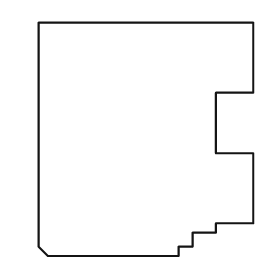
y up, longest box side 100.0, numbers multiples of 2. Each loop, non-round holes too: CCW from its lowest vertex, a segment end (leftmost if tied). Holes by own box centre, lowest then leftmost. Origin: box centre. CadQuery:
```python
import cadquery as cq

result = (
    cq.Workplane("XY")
    .moveTo(-42.0, -50.0)
    .lineTo(14.0, -50.0)
    .lineTo(14.0, -46.0)
    .lineTo(20.0, -46.0)
    .lineTo(20.0, -40.0)
    .lineTo(30.0, -40.0)
    .lineTo(30.0, -36.0)
    .lineTo(46.0, -36.0)
    .lineTo(46.0, -6.0)
    .lineTo(30.0, -6.0)
    .lineTo(30.0, 20.0)
    .lineTo(46.0, 20.0)
    .lineTo(46.0, 50.0)
    .lineTo(-46.0, 50.0)
    .lineTo(-46.0, -46.0)
    .close()
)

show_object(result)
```